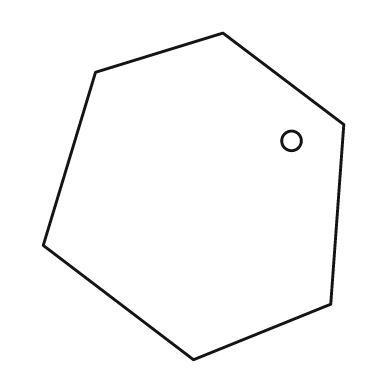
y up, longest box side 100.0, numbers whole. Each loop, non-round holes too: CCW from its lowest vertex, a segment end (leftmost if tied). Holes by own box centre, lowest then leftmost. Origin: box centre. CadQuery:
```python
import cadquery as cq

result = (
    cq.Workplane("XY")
    .moveTo(0.0, -50.0)
    .lineTo(42.0, -33.0)
    .lineTo(46.0, 22.0)
    .lineTo(9.0, 50.0)
    .lineTo(-30.0, 38.0)
    .lineTo(-46.0, -15.0)
    .close()
    .moveTo(30.0, 17.0)
    .circle(3.0)
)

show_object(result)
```